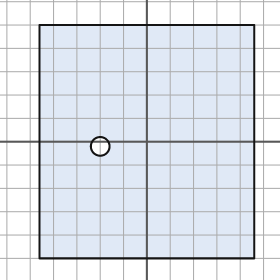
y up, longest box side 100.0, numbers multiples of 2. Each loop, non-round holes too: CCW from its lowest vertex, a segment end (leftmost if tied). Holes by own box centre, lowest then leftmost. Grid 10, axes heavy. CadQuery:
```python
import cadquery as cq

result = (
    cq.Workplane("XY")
    .moveTo(-46.0, -50.0)
    .lineTo(46.0, -50.0)
    .lineTo(46.0, 50.0)
    .lineTo(-46.0, 50.0)
    .close()
    .moveTo(-20.0, -2.0)
    .circle(4.0)
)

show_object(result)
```